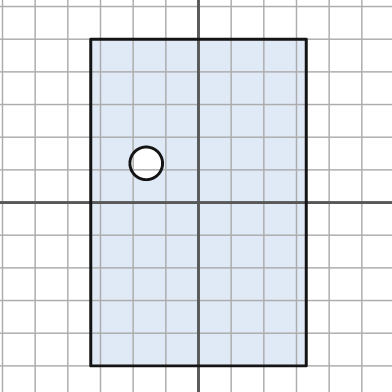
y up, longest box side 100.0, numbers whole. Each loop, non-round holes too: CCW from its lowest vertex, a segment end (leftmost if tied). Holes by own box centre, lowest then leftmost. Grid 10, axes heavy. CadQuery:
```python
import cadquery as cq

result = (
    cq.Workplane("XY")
    .moveTo(-33.0, -50.0)
    .lineTo(33.0, -50.0)
    .lineTo(33.0, 50.0)
    .lineTo(-33.0, 50.0)
    .close()
    .moveTo(-16.0, 12.0)
    .circle(5.0)
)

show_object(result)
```